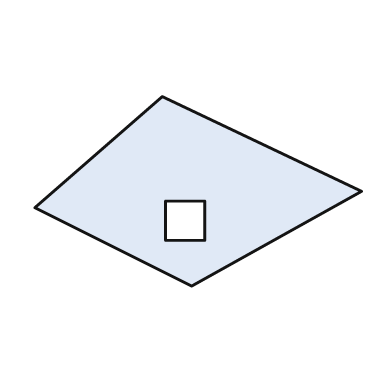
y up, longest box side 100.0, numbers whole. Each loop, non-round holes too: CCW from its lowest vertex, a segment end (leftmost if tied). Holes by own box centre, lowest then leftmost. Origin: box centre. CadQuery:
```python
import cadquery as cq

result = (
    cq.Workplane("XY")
    .moveTo(-2.0, -29.0)
    .lineTo(50.0, 0.0)
    .lineTo(-11.0, 29.0)
    .lineTo(-50.0, -5.0)
    .close()
    .moveTo(-10.0, -15.0)
    .lineTo(2.0, -15.0)
    .lineTo(2.0, -3.0)
    .lineTo(-10.0, -3.0)
    .close()
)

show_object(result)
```